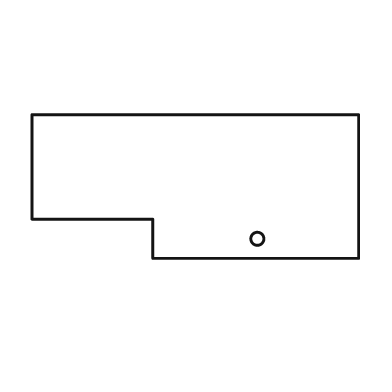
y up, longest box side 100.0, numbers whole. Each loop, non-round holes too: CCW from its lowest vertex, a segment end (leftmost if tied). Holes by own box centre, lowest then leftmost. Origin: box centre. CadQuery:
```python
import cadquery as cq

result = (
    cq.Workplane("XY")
    .moveTo(-13.0, -22.0)
    .lineTo(50.0, -22.0)
    .lineTo(50.0, 22.0)
    .lineTo(-50.0, 22.0)
    .lineTo(-50.0, -10.0)
    .lineTo(-13.0, -10.0)
    .close()
    .moveTo(19.0, -16.0)
    .circle(2.0)
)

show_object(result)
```